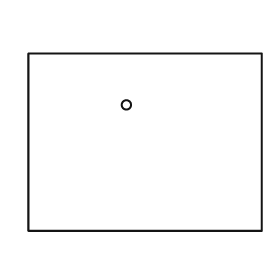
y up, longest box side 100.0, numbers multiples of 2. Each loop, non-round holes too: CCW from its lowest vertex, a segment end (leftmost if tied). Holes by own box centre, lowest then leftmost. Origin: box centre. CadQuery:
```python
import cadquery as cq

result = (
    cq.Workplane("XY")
    .moveTo(-50.0, -38.0)
    .lineTo(50.0, -38.0)
    .lineTo(50.0, 38.0)
    .lineTo(-50.0, 38.0)
    .close()
    .moveTo(-8.0, 16.0)
    .circle(2.0)
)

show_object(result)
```